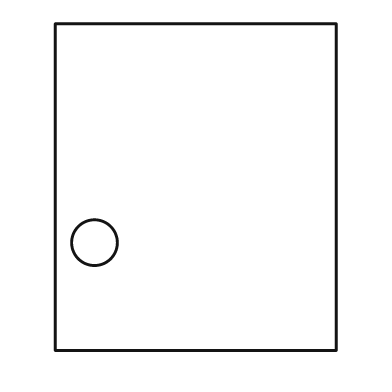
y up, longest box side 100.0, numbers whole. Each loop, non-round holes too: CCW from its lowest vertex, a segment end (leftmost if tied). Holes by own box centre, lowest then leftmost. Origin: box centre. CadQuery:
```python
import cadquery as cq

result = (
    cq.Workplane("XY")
    .moveTo(-43.0, -50.0)
    .lineTo(43.0, -50.0)
    .lineTo(43.0, 50.0)
    .lineTo(-43.0, 50.0)
    .close()
    .moveTo(-31.0, -17.0)
    .circle(7.0)
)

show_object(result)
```